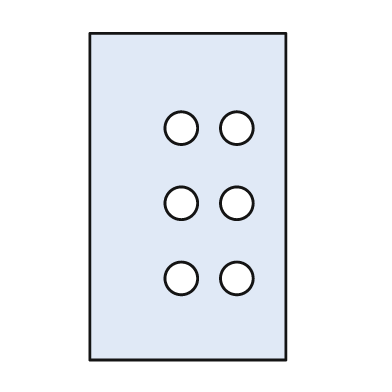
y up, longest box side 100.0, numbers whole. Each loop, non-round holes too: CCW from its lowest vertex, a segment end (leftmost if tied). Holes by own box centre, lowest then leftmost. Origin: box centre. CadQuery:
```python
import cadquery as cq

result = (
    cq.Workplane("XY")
    .moveTo(-30.0, -50.0)
    .lineTo(30.0, -50.0)
    .lineTo(30.0, 50.0)
    .lineTo(-30.0, 50.0)
    .close()
    .moveTo(-2.0, -25.0)
    .circle(5.0)
    .moveTo(15.0, -25.0)
    .circle(5.0)
    .moveTo(-2.0, -2.0)
    .circle(5.0)
    .moveTo(15.0, -2.0)
    .circle(5.0)
    .moveTo(-2.0, 21.0)
    .circle(5.0)
    .moveTo(15.0, 21.0)
    .circle(5.0)
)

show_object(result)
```